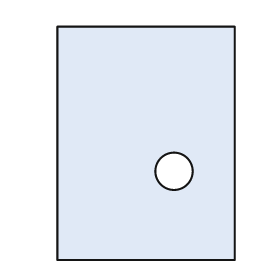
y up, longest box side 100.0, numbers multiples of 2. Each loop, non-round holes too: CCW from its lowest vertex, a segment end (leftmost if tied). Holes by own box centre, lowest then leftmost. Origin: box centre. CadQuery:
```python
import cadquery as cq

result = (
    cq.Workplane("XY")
    .moveTo(-38.0, -50.0)
    .lineTo(38.0, -50.0)
    .lineTo(38.0, 50.0)
    .lineTo(-38.0, 50.0)
    .close()
    .moveTo(12.0, -12.0)
    .circle(8.0)
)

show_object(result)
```